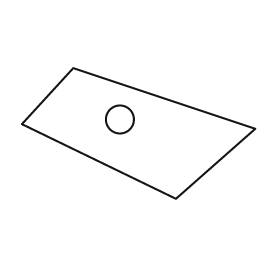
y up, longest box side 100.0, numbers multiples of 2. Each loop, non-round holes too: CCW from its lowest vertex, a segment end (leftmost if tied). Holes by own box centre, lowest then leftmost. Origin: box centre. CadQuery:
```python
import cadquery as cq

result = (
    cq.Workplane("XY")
    .moveTo(16.0, -28.0)
    .lineTo(50.0, 2.0)
    .lineTo(-28.0, 28.0)
    .lineTo(-50.0, 4.0)
    .close()
    .moveTo(-8.0, 6.0)
    .circle(6.0)
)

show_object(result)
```